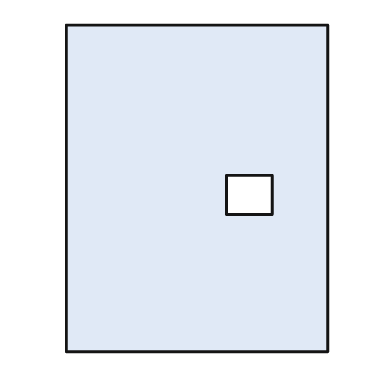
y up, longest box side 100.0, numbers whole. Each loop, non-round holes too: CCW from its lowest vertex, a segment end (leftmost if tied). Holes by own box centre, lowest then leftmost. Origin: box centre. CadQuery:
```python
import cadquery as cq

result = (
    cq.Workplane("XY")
    .moveTo(-40.0, -50.0)
    .lineTo(40.0, -50.0)
    .lineTo(40.0, 50.0)
    .lineTo(-40.0, 50.0)
    .close()
    .moveTo(9.0, -8.0)
    .lineTo(23.0, -8.0)
    .lineTo(23.0, 4.0)
    .lineTo(9.0, 4.0)
    .close()
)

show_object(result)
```